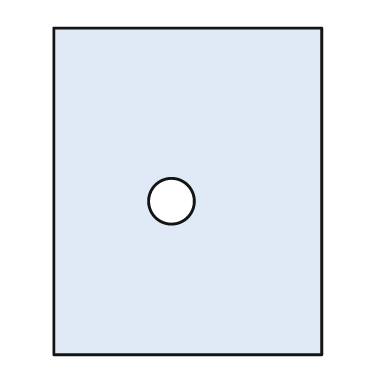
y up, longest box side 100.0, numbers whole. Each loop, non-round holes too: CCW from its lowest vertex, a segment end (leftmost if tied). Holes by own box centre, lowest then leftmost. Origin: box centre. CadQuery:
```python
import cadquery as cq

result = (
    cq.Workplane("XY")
    .moveTo(-41.0, -50.0)
    .lineTo(41.0, -50.0)
    .lineTo(41.0, 50.0)
    .lineTo(-41.0, 50.0)
    .close()
    .moveTo(-5.0, -3.0)
    .circle(7.0)
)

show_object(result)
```